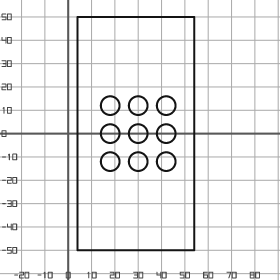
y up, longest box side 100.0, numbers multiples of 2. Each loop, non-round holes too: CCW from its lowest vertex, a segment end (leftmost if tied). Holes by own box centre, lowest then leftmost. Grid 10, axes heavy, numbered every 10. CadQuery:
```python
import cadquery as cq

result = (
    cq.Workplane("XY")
    .moveTo(4.0, -50.0)
    .lineTo(54.0, -50.0)
    .lineTo(54.0, 50.0)
    .lineTo(4.0, 50.0)
    .close()
    .moveTo(18.0, -12.0)
    .circle(4.0)
    .moveTo(30.0, -12.0)
    .circle(4.0)
    .moveTo(42.0, -12.0)
    .circle(4.0)
    .moveTo(18.0, 0.0)
    .circle(4.0)
    .moveTo(30.0, 0.0)
    .circle(4.0)
    .moveTo(42.0, 0.0)
    .circle(4.0)
    .moveTo(18.0, 12.0)
    .circle(4.0)
    .moveTo(30.0, 12.0)
    .circle(4.0)
    .moveTo(42.0, 12.0)
    .circle(4.0)
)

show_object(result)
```